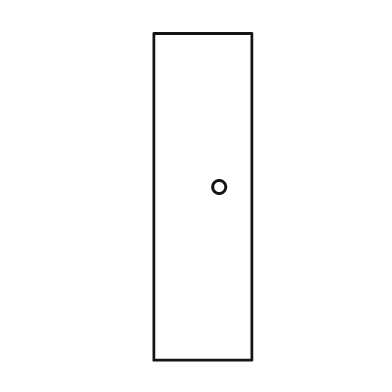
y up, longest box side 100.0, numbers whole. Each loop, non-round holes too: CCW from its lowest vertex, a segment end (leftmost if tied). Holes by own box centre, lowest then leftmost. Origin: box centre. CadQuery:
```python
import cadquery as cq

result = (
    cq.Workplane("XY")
    .moveTo(-15.0, -50.0)
    .lineTo(15.0, -50.0)
    .lineTo(15.0, 50.0)
    .lineTo(-15.0, 50.0)
    .close()
    .moveTo(5.0, 3.0)
    .circle(2.0)
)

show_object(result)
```